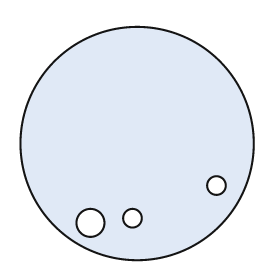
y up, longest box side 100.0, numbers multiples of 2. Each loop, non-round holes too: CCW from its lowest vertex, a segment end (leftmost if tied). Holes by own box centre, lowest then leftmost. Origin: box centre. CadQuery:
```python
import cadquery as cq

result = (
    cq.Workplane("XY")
    .moveTo(0.0, 0.0)
    .circle(50.0)
    .moveTo(-20.0, -34.0)
    .circle(6.0)
    .moveTo(-2.0, -32.0)
    .circle(4.0)
    .moveTo(34.0, -18.0)
    .circle(4.0)
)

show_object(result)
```